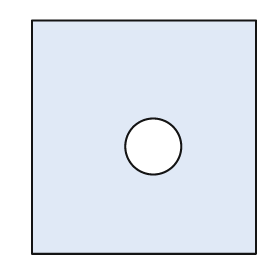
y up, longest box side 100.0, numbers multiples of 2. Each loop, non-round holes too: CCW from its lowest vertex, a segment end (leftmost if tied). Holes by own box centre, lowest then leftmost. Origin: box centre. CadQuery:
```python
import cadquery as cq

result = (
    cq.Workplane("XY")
    .moveTo(-48.0, -50.0)
    .lineTo(48.0, -50.0)
    .lineTo(48.0, 50.0)
    .lineTo(-48.0, 50.0)
    .close()
    .moveTo(4.0, -4.0)
    .circle(12.0)
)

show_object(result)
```